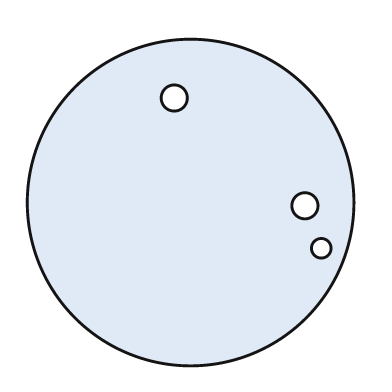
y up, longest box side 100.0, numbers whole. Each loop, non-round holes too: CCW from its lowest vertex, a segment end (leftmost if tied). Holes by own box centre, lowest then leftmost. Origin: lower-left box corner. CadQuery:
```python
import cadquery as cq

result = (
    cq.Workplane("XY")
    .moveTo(50.0, 50.0)
    .circle(50.0)
    .moveTo(90.0, 36.0)
    .circle(3.0)
    .moveTo(85.0, 49.0)
    .circle(4.0)
    .moveTo(45.0, 82.0)
    .circle(4.0)
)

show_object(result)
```